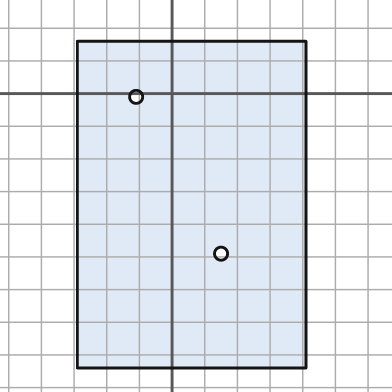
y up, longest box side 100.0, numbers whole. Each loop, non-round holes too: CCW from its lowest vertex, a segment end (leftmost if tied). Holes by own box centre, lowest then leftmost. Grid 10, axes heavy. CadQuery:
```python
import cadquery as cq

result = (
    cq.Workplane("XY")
    .moveTo(-29.0, -84.0)
    .lineTo(41.0, -84.0)
    .lineTo(41.0, 16.0)
    .lineTo(-29.0, 16.0)
    .close()
    .moveTo(15.0, -49.0)
    .circle(2.0)
    .moveTo(-11.0, -1.0)
    .circle(2.0)
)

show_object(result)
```